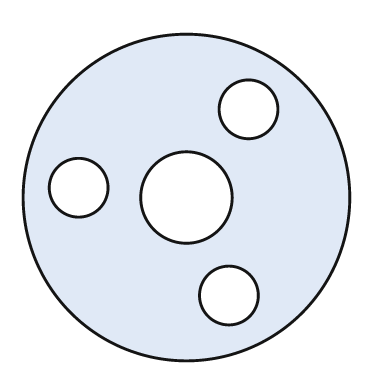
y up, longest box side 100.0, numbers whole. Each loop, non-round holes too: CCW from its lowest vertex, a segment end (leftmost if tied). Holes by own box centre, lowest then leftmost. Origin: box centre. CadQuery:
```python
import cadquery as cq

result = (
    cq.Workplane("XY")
    .moveTo(0.0, 0.0)
    .circle(50.0)
    .moveTo(13.0, -30.0)
    .circle(9.0)
    .moveTo(0.0, 0.0)
    .circle(14.0)
    .moveTo(-33.0, 3.0)
    .circle(9.0)
    .moveTo(19.0, 27.0)
    .circle(9.0)
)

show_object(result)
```